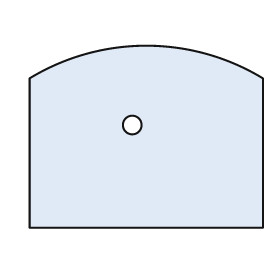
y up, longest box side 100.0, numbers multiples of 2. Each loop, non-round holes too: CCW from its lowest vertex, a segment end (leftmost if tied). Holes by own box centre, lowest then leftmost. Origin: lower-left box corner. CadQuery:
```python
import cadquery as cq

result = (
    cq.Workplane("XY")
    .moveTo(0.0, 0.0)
    .lineTo(100.0, 0.0)
    .lineTo(100.0, 64.0)
    .threePointArc((50.0, 78.0), (0.0, 64.0))
    .close()
    .moveTo(44.0, 44.0)
    .circle(4.0)
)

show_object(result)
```